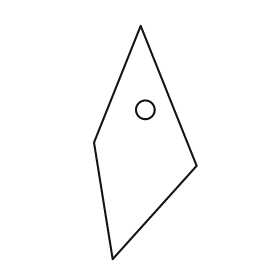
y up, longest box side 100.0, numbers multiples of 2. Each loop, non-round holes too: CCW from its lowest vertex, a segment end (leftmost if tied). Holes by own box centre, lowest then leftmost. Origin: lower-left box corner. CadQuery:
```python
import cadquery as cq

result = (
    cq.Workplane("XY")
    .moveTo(8.0, 0.0)
    .lineTo(44.0, 40.0)
    .lineTo(20.0, 100.0)
    .lineTo(0.0, 50.0)
    .close()
    .moveTo(22.0, 64.0)
    .circle(4.0)
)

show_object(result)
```